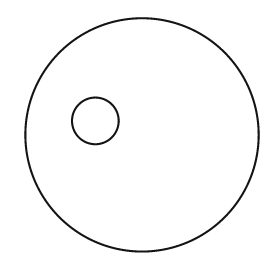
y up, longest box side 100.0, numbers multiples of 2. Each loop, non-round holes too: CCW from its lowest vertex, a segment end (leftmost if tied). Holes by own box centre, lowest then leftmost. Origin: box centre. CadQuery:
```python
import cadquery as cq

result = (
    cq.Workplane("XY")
    .moveTo(0.0, 0.0)
    .circle(50.0)
    .moveTo(-20.0, 6.0)
    .circle(10.0)
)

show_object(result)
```